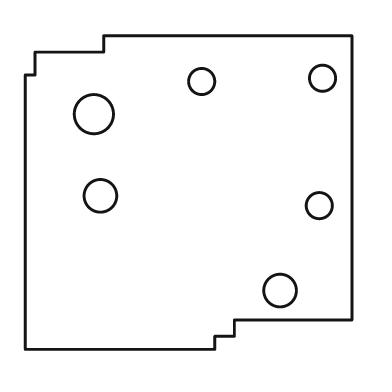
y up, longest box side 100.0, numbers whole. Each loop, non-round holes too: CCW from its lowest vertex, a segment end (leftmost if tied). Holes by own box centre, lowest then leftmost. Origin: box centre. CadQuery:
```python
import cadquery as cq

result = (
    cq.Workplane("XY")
    .moveTo(-50.0, -48.0)
    .lineTo(8.0, -48.0)
    .lineTo(8.0, -44.0)
    .lineTo(14.0, -44.0)
    .lineTo(14.0, -39.0)
    .lineTo(50.0, -39.0)
    .lineTo(50.0, 48.0)
    .lineTo(-26.0, 48.0)
    .lineTo(-26.0, 43.0)
    .lineTo(-47.0, 43.0)
    .lineTo(-47.0, 36.0)
    .lineTo(-50.0, 36.0)
    .close()
    .moveTo(28.0, -30.0)
    .circle(5.0)
    .moveTo(40.0, -4.0)
    .circle(4.0)
    .moveTo(-27.0, -1.0)
    .circle(5.0)
    .moveTo(-29.0, 24.0)
    .circle(6.0)
    .moveTo(4.0, 34.0)
    .circle(4.0)
    .moveTo(41.0, 35.0)
    .circle(4.0)
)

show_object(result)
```